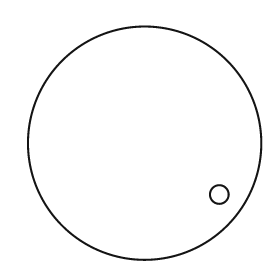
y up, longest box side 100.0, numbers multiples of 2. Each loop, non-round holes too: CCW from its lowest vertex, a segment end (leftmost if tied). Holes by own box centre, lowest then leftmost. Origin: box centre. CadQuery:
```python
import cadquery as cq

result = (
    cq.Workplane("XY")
    .moveTo(0.0, 0.0)
    .circle(50.0)
    .moveTo(32.0, -22.0)
    .circle(4.0)
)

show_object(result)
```